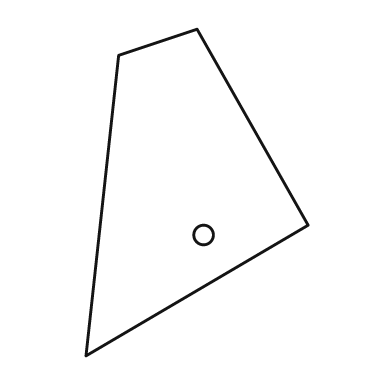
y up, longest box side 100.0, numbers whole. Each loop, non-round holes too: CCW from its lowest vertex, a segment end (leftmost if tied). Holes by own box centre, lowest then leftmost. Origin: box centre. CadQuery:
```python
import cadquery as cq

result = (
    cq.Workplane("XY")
    .moveTo(-34.0, -50.0)
    .lineTo(34.0, -10.0)
    .lineTo(0.0, 50.0)
    .lineTo(-24.0, 42.0)
    .close()
    .moveTo(2.0, -13.0)
    .circle(3.0)
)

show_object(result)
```